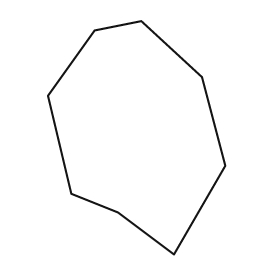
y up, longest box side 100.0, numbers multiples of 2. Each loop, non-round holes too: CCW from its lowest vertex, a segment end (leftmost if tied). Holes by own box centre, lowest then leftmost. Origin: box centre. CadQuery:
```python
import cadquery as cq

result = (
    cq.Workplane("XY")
    .moveTo(16.0, -50.0)
    .lineTo(38.0, -12.0)
    .lineTo(28.0, 26.0)
    .lineTo(2.0, 50.0)
    .lineTo(-18.0, 46.0)
    .lineTo(-38.0, 18.0)
    .lineTo(-28.0, -24.0)
    .lineTo(-8.0, -32.0)
    .close()
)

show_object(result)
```